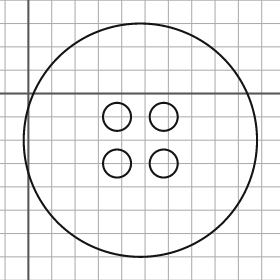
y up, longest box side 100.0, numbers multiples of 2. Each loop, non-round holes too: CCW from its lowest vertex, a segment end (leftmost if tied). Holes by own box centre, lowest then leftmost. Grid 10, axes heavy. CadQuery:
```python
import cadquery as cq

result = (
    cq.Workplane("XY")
    .moveTo(48.0, -20.0)
    .circle(50.0)
    .moveTo(38.0, -30.0)
    .circle(6.0)
    .moveTo(58.0, -30.0)
    .circle(6.0)
    .moveTo(38.0, -10.0)
    .circle(6.0)
    .moveTo(58.0, -10.0)
    .circle(6.0)
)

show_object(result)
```